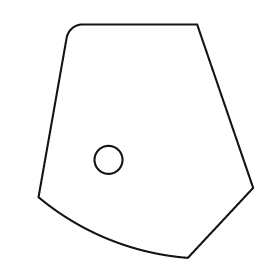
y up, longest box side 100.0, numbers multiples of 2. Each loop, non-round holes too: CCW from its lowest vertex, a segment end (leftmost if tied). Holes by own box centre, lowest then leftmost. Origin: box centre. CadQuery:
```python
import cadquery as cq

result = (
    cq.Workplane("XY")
    .moveTo(18.0, -50.0)
    .lineTo(46.0, -20.0)
    .lineTo(22.0, 50.0)
    .lineTo(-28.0, 50.0)
    .threePointArc((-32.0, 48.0), (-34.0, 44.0))
    .lineTo(-46.0, -24.0)
    .threePointArc((-16.0, -42.0), (18.0, -50.0))
    .close()
    .moveTo(-16.0, -8.0)
    .circle(6.0)
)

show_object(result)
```